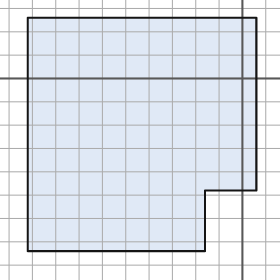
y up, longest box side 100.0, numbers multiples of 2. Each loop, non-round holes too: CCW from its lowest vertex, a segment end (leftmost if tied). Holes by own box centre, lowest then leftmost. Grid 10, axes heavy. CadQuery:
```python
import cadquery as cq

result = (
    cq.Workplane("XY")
    .moveTo(-92.0, -74.0)
    .lineTo(-16.0, -74.0)
    .lineTo(-16.0, -48.0)
    .lineTo(6.0, -48.0)
    .lineTo(6.0, 26.0)
    .lineTo(-92.0, 26.0)
    .close()
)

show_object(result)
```